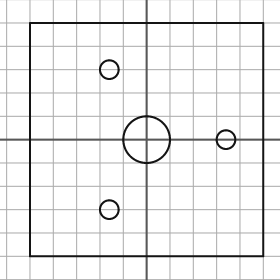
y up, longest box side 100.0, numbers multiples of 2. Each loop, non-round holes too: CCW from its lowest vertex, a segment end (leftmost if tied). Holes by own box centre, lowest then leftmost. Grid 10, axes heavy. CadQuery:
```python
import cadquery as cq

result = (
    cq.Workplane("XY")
    .moveTo(-50.0, -50.0)
    .lineTo(50.0, -50.0)
    .lineTo(50.0, 50.0)
    .lineTo(-50.0, 50.0)
    .close()
    .moveTo(-16.0, -30.0)
    .circle(4.0)
    .moveTo(0.0, 0.0)
    .circle(10.0)
    .moveTo(34.0, 0.0)
    .circle(4.0)
    .moveTo(-16.0, 30.0)
    .circle(4.0)
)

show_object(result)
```